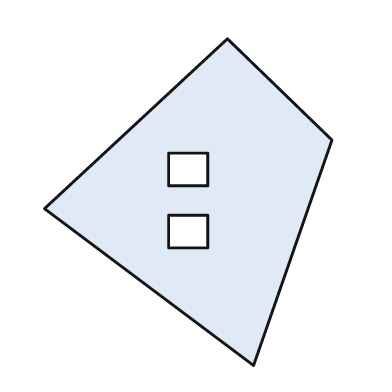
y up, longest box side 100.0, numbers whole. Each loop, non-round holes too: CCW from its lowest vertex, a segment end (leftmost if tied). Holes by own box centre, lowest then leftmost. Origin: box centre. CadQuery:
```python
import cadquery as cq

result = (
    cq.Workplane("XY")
    .moveTo(20.0, -50.0)
    .lineTo(44.0, 19.0)
    .lineTo(12.0, 50.0)
    .lineTo(-44.0, -2.0)
    .close()
    .moveTo(-6.0, -14.0)
    .lineTo(6.0, -14.0)
    .lineTo(6.0, -4.0)
    .lineTo(-6.0, -4.0)
    .close()
    .moveTo(-6.0, 5.0)
    .lineTo(6.0, 5.0)
    .lineTo(6.0, 15.0)
    .lineTo(-6.0, 15.0)
    .close()
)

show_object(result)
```